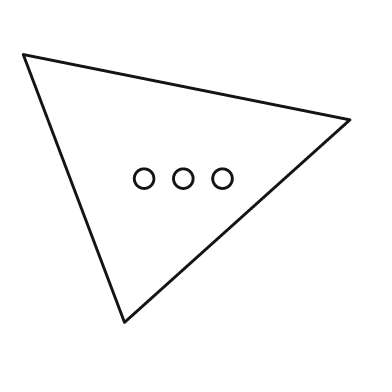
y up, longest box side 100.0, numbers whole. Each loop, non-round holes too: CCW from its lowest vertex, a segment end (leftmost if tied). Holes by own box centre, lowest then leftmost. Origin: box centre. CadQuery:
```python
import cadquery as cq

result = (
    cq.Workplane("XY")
    .moveTo(-19.0, -41.0)
    .lineTo(50.0, 21.0)
    .lineTo(-50.0, 41.0)
    .close()
    .moveTo(-13.0, 3.0)
    .circle(3.0)
    .moveTo(-1.0, 3.0)
    .circle(3.0)
    .moveTo(11.0, 3.0)
    .circle(3.0)
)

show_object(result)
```